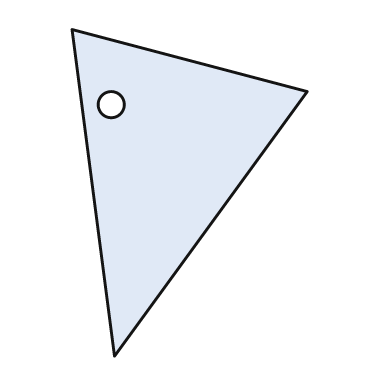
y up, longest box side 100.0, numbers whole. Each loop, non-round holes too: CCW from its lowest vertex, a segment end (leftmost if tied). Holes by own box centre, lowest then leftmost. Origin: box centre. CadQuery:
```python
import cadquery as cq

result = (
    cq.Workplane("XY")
    .moveTo(-23.0, -50.0)
    .lineTo(36.0, 31.0)
    .lineTo(-36.0, 50.0)
    .close()
    .moveTo(-24.0, 27.0)
    .circle(4.0)
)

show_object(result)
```